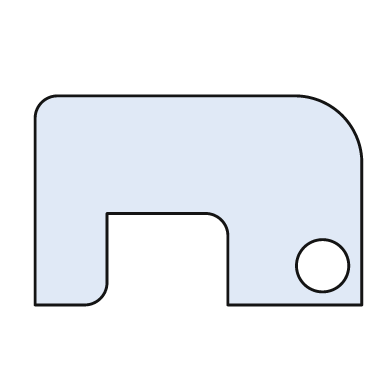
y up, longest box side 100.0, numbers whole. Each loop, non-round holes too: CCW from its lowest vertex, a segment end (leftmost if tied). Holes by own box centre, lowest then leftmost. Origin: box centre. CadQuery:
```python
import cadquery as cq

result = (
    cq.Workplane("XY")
    .moveTo(-50.0, -32.0)
    .lineTo(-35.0, -32.0)
    .threePointArc((-30.0, -30.0), (-28.0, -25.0))
    .lineTo(-28.0, -4.0)
    .lineTo(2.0, -4.0)
    .threePointArc((7.0, -6.0), (9.0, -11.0))
    .lineTo(9.0, -32.0)
    .lineTo(50.0, -32.0)
    .lineTo(50.0, 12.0)
    .threePointArc((44.0, 26.0), (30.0, 32.0))
    .lineTo(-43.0, 32.0)
    .threePointArc((-48.0, 30.0), (-50.0, 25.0))
    .close()
    .moveTo(38.0, -20.0)
    .circle(8.0)
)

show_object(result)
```